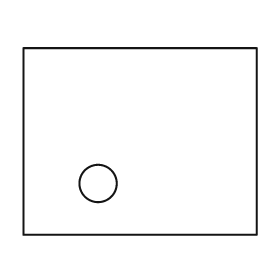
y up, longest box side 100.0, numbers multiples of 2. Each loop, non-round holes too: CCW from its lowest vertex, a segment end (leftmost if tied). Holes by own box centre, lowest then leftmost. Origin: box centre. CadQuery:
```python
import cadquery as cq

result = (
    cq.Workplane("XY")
    .moveTo(-50.0, -40.0)
    .lineTo(50.0, -40.0)
    .lineTo(50.0, 40.0)
    .lineTo(-50.0, 40.0)
    .close()
    .moveTo(-18.0, -18.0)
    .circle(8.0)
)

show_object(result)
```